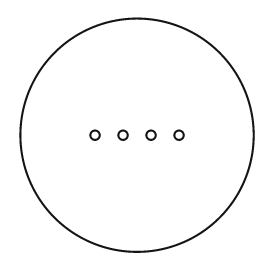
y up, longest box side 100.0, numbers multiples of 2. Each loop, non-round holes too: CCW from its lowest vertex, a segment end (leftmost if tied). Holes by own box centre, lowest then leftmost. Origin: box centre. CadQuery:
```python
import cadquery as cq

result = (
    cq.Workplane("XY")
    .moveTo(0.0, 0.0)
    .circle(50.0)
    .moveTo(-18.0, 0.0)
    .circle(2.0)
    .moveTo(-6.0, 0.0)
    .circle(2.0)
    .moveTo(6.0, 0.0)
    .circle(2.0)
    .moveTo(18.0, 0.0)
    .circle(2.0)
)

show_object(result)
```